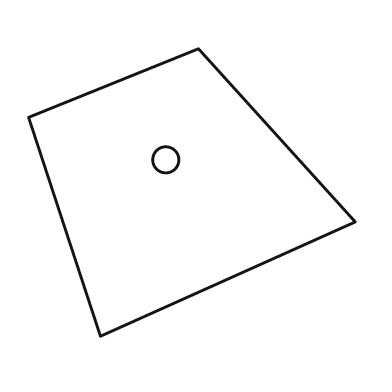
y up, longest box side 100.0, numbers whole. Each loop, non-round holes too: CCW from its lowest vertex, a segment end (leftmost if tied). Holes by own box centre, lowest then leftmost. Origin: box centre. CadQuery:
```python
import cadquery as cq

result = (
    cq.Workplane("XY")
    .moveTo(-28.0, -44.0)
    .lineTo(50.0, -9.0)
    .lineTo(2.0, 44.0)
    .lineTo(-50.0, 23.0)
    .close()
    .moveTo(-8.0, 10.0)
    .circle(4.0)
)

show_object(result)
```